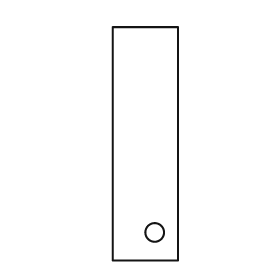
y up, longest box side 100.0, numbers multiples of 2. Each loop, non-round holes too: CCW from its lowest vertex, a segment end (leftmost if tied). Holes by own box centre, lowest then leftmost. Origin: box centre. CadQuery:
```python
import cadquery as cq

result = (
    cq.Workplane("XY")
    .moveTo(-14.0, -50.0)
    .lineTo(14.0, -50.0)
    .lineTo(14.0, 50.0)
    .lineTo(-14.0, 50.0)
    .close()
    .moveTo(4.0, -38.0)
    .circle(4.0)
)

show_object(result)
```